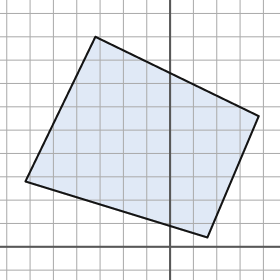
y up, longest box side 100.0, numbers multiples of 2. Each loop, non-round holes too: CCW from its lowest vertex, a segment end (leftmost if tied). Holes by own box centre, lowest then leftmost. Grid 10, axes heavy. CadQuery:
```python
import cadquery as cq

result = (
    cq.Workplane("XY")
    .moveTo(16.0, 4.0)
    .lineTo(38.0, 56.0)
    .lineTo(-32.0, 90.0)
    .lineTo(-62.0, 28.0)
    .close()
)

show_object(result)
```